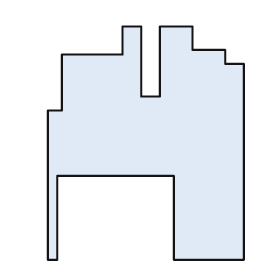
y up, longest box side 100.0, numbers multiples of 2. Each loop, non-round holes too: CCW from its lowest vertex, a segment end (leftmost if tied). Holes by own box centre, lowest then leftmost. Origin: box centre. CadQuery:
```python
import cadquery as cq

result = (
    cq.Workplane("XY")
    .moveTo(-42.0, -50.0)
    .lineTo(-38.0, -50.0)
    .lineTo(-38.0, -14.0)
    .lineTo(12.0, -14.0)
    .lineTo(12.0, -50.0)
    .lineTo(42.0, -50.0)
    .lineTo(42.0, 34.0)
    .lineTo(34.0, 34.0)
    .lineTo(34.0, 40.0)
    .lineTo(20.0, 40.0)
    .lineTo(20.0, 50.0)
    .lineTo(6.0, 50.0)
    .lineTo(6.0, 20.0)
    .lineTo(-2.0, 20.0)
    .lineTo(-2.0, 50.0)
    .lineTo(-10.0, 50.0)
    .lineTo(-10.0, 38.0)
    .lineTo(-36.0, 38.0)
    .lineTo(-36.0, 14.0)
    .lineTo(-42.0, 14.0)
    .close()
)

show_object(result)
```